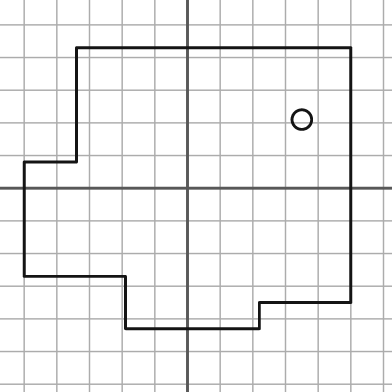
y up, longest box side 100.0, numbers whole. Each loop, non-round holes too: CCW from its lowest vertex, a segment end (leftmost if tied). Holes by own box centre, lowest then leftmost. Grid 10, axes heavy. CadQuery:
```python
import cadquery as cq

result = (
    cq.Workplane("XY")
    .moveTo(-19.0, -43.0)
    .lineTo(22.0, -43.0)
    .lineTo(22.0, -35.0)
    .lineTo(50.0, -35.0)
    .lineTo(50.0, 43.0)
    .lineTo(-34.0, 43.0)
    .lineTo(-34.0, 8.0)
    .lineTo(-50.0, 8.0)
    .lineTo(-50.0, -27.0)
    .lineTo(-19.0, -27.0)
    .close()
    .moveTo(35.0, 21.0)
    .circle(3.0)
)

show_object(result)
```